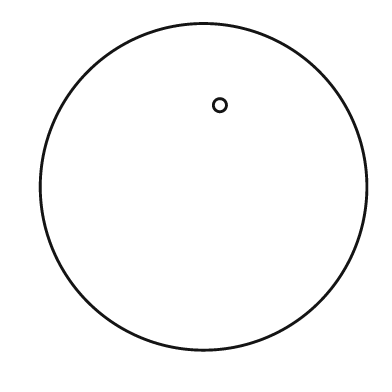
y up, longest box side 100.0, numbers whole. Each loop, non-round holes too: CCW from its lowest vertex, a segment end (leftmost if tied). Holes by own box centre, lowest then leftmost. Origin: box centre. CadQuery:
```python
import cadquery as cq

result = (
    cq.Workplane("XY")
    .moveTo(0.0, 0.0)
    .circle(50.0)
    .moveTo(5.0, 25.0)
    .circle(2.0)
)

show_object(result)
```